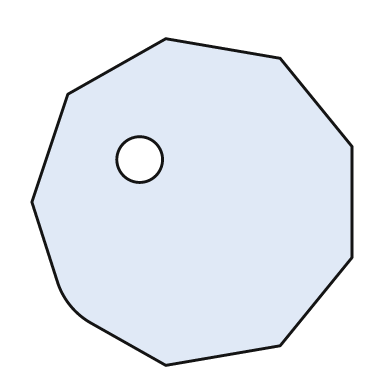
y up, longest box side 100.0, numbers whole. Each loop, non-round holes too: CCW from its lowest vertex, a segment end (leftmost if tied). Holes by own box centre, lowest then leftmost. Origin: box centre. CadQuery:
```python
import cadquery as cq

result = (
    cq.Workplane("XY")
    .moveTo(-8.0, -50.0)
    .lineTo(27.0, -44.0)
    .lineTo(49.0, -17.0)
    .lineTo(49.0, 17.0)
    .lineTo(27.0, 44.0)
    .lineTo(-8.0, 50.0)
    .lineTo(-38.0, 33.0)
    .lineTo(-49.0, 0.0)
    .lineTo(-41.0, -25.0)
    .threePointArc((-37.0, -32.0), (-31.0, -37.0))
    .close()
    .moveTo(-16.0, 13.0)
    .circle(7.0)
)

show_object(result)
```